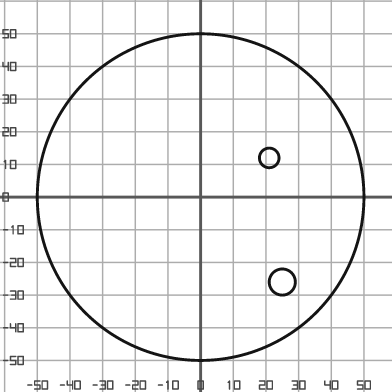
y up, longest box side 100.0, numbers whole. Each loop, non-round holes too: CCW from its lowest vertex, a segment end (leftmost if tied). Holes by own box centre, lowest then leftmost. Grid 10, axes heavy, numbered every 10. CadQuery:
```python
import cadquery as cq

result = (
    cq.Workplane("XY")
    .moveTo(0.0, 0.0)
    .circle(50.0)
    .moveTo(25.0, -26.0)
    .circle(4.0)
    .moveTo(21.0, 12.0)
    .circle(3.0)
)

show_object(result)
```